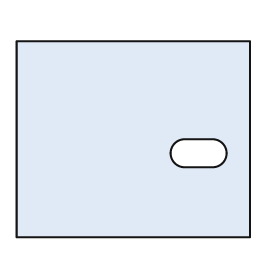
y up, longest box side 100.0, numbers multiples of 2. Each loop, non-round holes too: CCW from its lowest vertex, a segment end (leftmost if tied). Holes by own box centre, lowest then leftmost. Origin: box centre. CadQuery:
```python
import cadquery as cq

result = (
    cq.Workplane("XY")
    .moveTo(-50.0, -42.0)
    .lineTo(50.0, -42.0)
    .lineTo(50.0, 42.0)
    .lineTo(-50.0, 42.0)
    .close()
    .moveTo(22.0, -12.0)
    .lineTo(34.0, -12.0)
    .threePointArc((40.0, -6.0), (34.0, 0.0))
    .lineTo(22.0, 0.0)
    .threePointArc((16.0, -6.0), (22.0, -12.0))
    .close()
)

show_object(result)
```